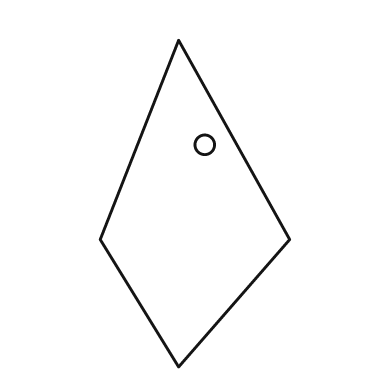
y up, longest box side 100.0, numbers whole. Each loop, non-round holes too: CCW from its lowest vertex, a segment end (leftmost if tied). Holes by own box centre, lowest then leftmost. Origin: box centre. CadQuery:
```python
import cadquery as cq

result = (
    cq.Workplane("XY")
    .moveTo(-5.0, -50.0)
    .lineTo(29.0, -11.0)
    .lineTo(-5.0, 50.0)
    .lineTo(-29.0, -11.0)
    .close()
    .moveTo(3.0, 18.0)
    .circle(3.0)
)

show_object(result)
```